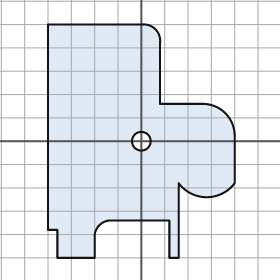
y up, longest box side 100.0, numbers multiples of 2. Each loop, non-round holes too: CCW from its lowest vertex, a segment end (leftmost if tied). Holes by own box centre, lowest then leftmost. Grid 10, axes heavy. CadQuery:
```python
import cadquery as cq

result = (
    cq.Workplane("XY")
    .moveTo(-36.0, -50.0)
    .lineTo(-20.0, -50.0)
    .lineTo(-20.0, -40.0)
    .threePointArc((-18.0, -36.0), (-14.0, -34.0))
    .lineTo(12.0, -34.0)
    .lineTo(12.0, -50.0)
    .lineTo(16.0, -50.0)
    .lineTo(16.0, -18.0)
    .threePointArc((28.0, -24.0), (40.0, -18.0))
    .lineTo(40.0, 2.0)
    .threePointArc((36.0, 12.0), (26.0, 16.0))
    .lineTo(8.0, 16.0)
    .lineTo(8.0, 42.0)
    .threePointArc((6.0, 48.0), (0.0, 50.0))
    .lineTo(-40.0, 50.0)
    .lineTo(-40.0, -38.0)
    .lineTo(-36.0, -38.0)
    .close()
    .moveTo(0.0, 0.0)
    .circle(4.0)
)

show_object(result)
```